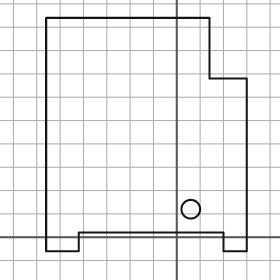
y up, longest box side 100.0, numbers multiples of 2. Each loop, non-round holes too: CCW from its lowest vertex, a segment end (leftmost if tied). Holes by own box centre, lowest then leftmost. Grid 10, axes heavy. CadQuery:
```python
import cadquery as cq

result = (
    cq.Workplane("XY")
    .moveTo(-56.0, -6.0)
    .lineTo(-42.0, -6.0)
    .lineTo(-42.0, 2.0)
    .lineTo(20.0, 2.0)
    .lineTo(20.0, -6.0)
    .lineTo(30.0, -6.0)
    .lineTo(30.0, 68.0)
    .lineTo(14.0, 68.0)
    .lineTo(14.0, 94.0)
    .lineTo(-56.0, 94.0)
    .close()
    .moveTo(6.0, 12.0)
    .circle(4.0)
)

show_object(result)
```